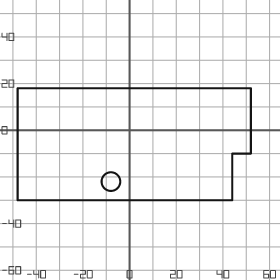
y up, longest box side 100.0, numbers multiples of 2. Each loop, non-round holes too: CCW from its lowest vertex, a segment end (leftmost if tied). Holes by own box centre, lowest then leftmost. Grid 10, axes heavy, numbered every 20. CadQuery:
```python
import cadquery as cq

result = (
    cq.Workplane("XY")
    .moveTo(-48.0, -30.0)
    .lineTo(44.0, -30.0)
    .lineTo(44.0, -10.0)
    .lineTo(52.0, -10.0)
    .lineTo(52.0, 18.0)
    .lineTo(-48.0, 18.0)
    .close()
    .moveTo(-8.0, -22.0)
    .circle(4.0)
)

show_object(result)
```